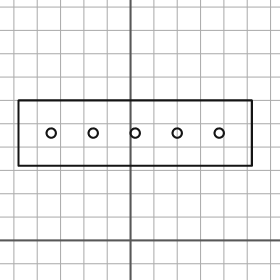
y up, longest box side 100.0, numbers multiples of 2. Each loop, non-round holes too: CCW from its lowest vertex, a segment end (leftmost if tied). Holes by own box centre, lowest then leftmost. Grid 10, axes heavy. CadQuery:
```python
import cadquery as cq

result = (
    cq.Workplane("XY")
    .moveTo(-48.0, 32.0)
    .lineTo(52.0, 32.0)
    .lineTo(52.0, 60.0)
    .lineTo(-48.0, 60.0)
    .close()
    .moveTo(-34.0, 46.0)
    .circle(2.0)
    .moveTo(-16.0, 46.0)
    .circle(2.0)
    .moveTo(2.0, 46.0)
    .circle(2.0)
    .moveTo(20.0, 46.0)
    .circle(2.0)
    .moveTo(38.0, 46.0)
    .circle(2.0)
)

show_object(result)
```